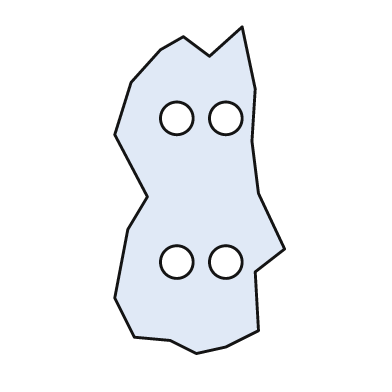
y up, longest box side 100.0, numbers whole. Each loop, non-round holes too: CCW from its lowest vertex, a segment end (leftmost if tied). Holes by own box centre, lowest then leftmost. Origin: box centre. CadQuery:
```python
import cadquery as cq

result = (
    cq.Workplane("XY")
    .moveTo(-1.0, -50.0)
    .lineTo(8.0, -48.0)
    .lineTo(18.0, -43.0)
    .lineTo(17.0, -25.0)
    .lineTo(26.0, -18.0)
    .lineTo(18.0, -1.0)
    .lineTo(16.0, 15.0)
    .lineTo(17.0, 31.0)
    .lineTo(13.0, 50.0)
    .lineTo(3.0, 41.0)
    .lineTo(-5.0, 47.0)
    .lineTo(-12.0, 43.0)
    .lineTo(-21.0, 33.0)
    .lineTo(-26.0, 17.0)
    .lineTo(-16.0, -2.0)
    .lineTo(-22.0, -12.0)
    .lineTo(-26.0, -33.0)
    .lineTo(-20.0, -45.0)
    .lineTo(-9.0, -46.0)
    .close()
    .moveTo(-7.0, -22.0)
    .circle(5.0)
    .moveTo(8.0, -22.0)
    .circle(5.0)
    .moveTo(-7.0, 22.0)
    .circle(5.0)
    .moveTo(8.0, 22.0)
    .circle(5.0)
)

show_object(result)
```